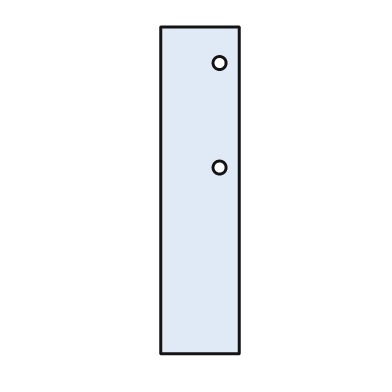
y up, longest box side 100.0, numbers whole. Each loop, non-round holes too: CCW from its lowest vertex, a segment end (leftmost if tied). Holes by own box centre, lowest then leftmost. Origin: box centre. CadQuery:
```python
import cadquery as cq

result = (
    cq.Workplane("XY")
    .moveTo(-12.0, -50.0)
    .lineTo(12.0, -50.0)
    .lineTo(12.0, 50.0)
    .lineTo(-12.0, 50.0)
    .close()
    .moveTo(6.0, 7.0)
    .circle(2.0)
    .moveTo(6.0, 39.0)
    .circle(2.0)
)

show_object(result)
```